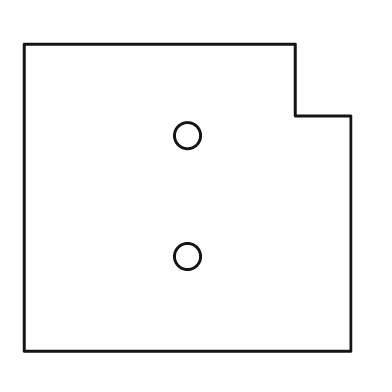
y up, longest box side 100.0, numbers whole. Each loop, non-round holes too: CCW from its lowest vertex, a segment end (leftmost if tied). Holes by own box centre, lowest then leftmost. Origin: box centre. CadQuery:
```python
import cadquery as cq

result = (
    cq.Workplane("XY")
    .moveTo(-50.0, -47.0)
    .lineTo(50.0, -47.0)
    .lineTo(50.0, 25.0)
    .lineTo(33.0, 25.0)
    .lineTo(33.0, 47.0)
    .lineTo(-50.0, 47.0)
    .close()
    .moveTo(0.0, -18.0)
    .circle(4.0)
    .moveTo(0.0, 19.0)
    .circle(4.0)
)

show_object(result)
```